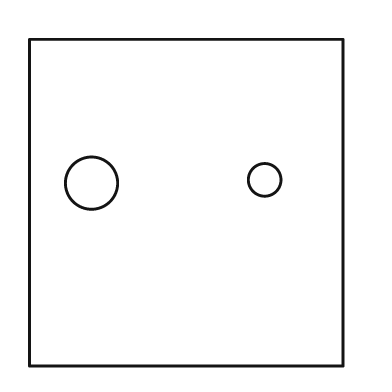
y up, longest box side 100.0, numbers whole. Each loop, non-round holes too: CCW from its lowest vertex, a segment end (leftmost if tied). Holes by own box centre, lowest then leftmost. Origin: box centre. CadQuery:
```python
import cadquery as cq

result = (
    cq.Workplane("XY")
    .moveTo(-48.0, -50.0)
    .lineTo(48.0, -50.0)
    .lineTo(48.0, 50.0)
    .lineTo(-48.0, 50.0)
    .close()
    .moveTo(-29.0, 6.0)
    .circle(8.0)
    .moveTo(24.0, 7.0)
    .circle(5.0)
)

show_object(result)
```